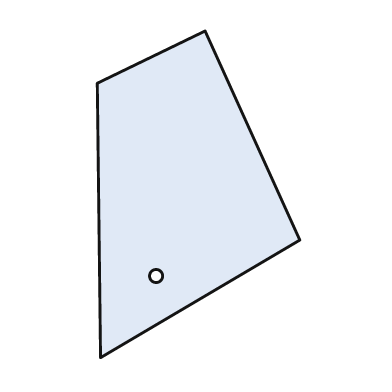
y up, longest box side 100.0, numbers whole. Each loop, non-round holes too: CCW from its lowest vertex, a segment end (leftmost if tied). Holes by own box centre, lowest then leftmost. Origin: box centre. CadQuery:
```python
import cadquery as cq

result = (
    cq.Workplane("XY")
    .moveTo(-30.0, -50.0)
    .lineTo(31.0, -14.0)
    .lineTo(2.0, 50.0)
    .lineTo(-31.0, 34.0)
    .close()
    .moveTo(-13.0, -25.0)
    .circle(2.0)
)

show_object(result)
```